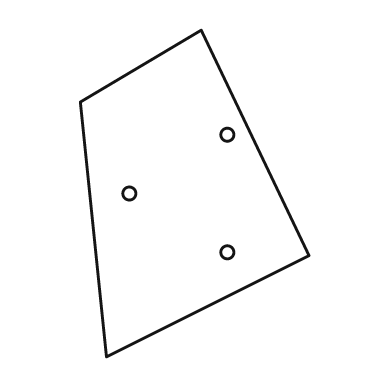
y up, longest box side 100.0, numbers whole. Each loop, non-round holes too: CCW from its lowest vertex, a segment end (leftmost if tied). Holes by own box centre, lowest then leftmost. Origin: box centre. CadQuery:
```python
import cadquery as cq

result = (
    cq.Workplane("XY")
    .moveTo(-27.0, -50.0)
    .lineTo(35.0, -19.0)
    .lineTo(2.0, 50.0)
    .lineTo(-35.0, 28.0)
    .close()
    .moveTo(10.0, -18.0)
    .circle(2.0)
    .moveTo(-20.0, 0.0)
    .circle(2.0)
    .moveTo(10.0, 18.0)
    .circle(2.0)
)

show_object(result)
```